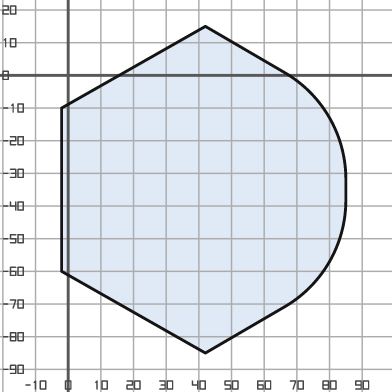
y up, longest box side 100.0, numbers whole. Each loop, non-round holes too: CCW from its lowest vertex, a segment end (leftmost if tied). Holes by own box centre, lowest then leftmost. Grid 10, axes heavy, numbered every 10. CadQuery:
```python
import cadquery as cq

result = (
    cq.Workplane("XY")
    .moveTo(42.0, -85.0)
    .lineTo(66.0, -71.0)
    .threePointArc((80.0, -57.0), (85.0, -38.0))
    .lineTo(85.0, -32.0)
    .threePointArc((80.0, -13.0), (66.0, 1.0))
    .lineTo(42.0, 15.0)
    .lineTo(-2.0, -10.0)
    .lineTo(-2.0, -60.0)
    .close()
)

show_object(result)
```